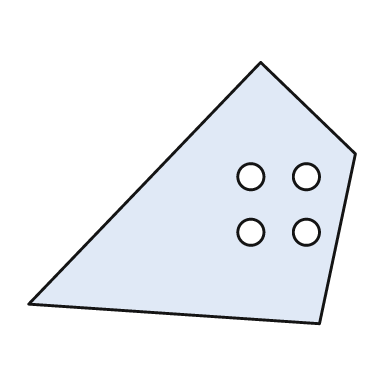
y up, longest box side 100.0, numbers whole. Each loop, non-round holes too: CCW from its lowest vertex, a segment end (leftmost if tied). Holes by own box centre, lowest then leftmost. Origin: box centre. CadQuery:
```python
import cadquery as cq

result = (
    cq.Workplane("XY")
    .moveTo(39.0, -40.0)
    .lineTo(50.0, 12.0)
    .lineTo(21.0, 40.0)
    .lineTo(-50.0, -34.0)
    .close()
    .moveTo(18.0, -12.0)
    .circle(4.0)
    .moveTo(35.0, -12.0)
    .circle(4.0)
    .moveTo(18.0, 5.0)
    .circle(4.0)
    .moveTo(35.0, 5.0)
    .circle(4.0)
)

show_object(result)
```